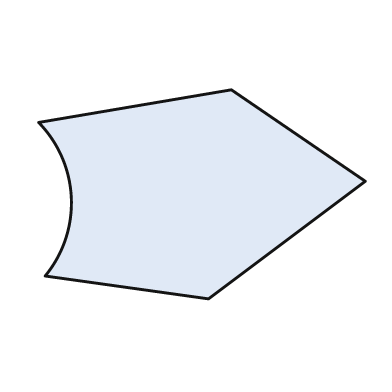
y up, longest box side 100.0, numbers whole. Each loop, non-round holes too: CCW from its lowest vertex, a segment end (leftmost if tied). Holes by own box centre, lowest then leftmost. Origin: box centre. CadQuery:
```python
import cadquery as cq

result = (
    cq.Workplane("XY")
    .moveTo(2.0, -32.0)
    .lineTo(50.0, 4.0)
    .lineTo(9.0, 32.0)
    .lineTo(-50.0, 22.0)
    .threePointArc((-40.0, -1.0), (-48.0, -25.0))
    .close()
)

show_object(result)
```